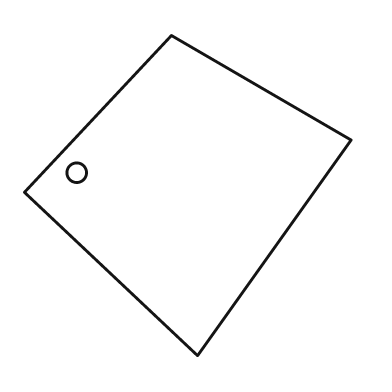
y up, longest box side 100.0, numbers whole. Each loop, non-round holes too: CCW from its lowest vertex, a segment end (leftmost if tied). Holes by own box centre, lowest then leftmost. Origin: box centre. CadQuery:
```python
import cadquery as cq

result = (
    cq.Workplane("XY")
    .moveTo(3.0, -49.0)
    .lineTo(50.0, 17.0)
    .lineTo(-5.0, 49.0)
    .lineTo(-50.0, 1.0)
    .close()
    .moveTo(-34.0, 7.0)
    .circle(3.0)
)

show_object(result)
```